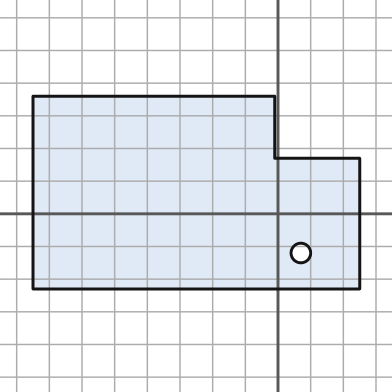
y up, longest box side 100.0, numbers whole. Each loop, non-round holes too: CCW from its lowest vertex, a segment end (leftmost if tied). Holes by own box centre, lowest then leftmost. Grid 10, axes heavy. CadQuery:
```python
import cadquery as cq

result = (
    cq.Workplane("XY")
    .moveTo(-75.0, -23.0)
    .lineTo(25.0, -23.0)
    .lineTo(25.0, 17.0)
    .lineTo(-1.0, 17.0)
    .lineTo(-1.0, 36.0)
    .lineTo(-75.0, 36.0)
    .close()
    .moveTo(7.0, -12.0)
    .circle(3.0)
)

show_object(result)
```